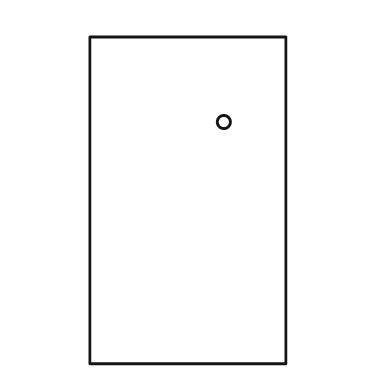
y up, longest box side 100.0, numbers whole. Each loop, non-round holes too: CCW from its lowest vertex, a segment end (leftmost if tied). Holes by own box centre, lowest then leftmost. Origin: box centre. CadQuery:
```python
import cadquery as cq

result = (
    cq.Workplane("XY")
    .moveTo(-30.0, -50.0)
    .lineTo(30.0, -50.0)
    .lineTo(30.0, 50.0)
    .lineTo(-30.0, 50.0)
    .close()
    .moveTo(11.0, 24.0)
    .circle(2.0)
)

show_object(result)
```